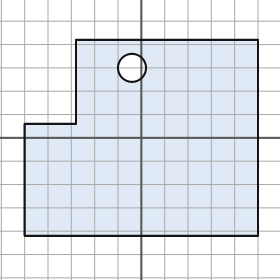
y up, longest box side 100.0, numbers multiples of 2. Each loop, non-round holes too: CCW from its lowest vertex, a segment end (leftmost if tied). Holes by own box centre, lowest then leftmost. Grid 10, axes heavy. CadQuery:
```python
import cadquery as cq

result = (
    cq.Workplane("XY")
    .moveTo(-50.0, -42.0)
    .lineTo(50.0, -42.0)
    .lineTo(50.0, 42.0)
    .lineTo(-28.0, 42.0)
    .lineTo(-28.0, 6.0)
    .lineTo(-50.0, 6.0)
    .close()
    .moveTo(-4.0, 30.0)
    .circle(6.0)
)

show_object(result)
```